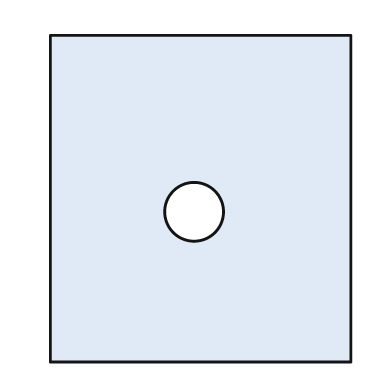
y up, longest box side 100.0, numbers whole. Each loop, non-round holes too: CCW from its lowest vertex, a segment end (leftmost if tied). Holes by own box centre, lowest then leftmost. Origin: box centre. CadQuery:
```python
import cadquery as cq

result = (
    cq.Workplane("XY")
    .moveTo(-46.0, -50.0)
    .lineTo(46.0, -50.0)
    .lineTo(46.0, 50.0)
    .lineTo(-46.0, 50.0)
    .close()
    .moveTo(-2.0, -4.0)
    .circle(9.0)
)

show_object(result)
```